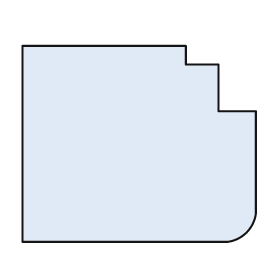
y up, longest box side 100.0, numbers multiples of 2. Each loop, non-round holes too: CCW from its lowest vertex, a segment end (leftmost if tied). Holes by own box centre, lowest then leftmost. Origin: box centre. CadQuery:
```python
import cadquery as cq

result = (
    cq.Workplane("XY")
    .moveTo(-50.0, -42.0)
    .lineTo(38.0, -42.0)
    .threePointArc((46.0, -38.0), (50.0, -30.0))
    .lineTo(50.0, 14.0)
    .lineTo(34.0, 14.0)
    .lineTo(34.0, 34.0)
    .lineTo(20.0, 34.0)
    .lineTo(20.0, 42.0)
    .lineTo(-50.0, 42.0)
    .close()
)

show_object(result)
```